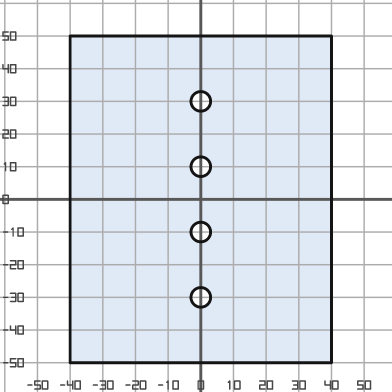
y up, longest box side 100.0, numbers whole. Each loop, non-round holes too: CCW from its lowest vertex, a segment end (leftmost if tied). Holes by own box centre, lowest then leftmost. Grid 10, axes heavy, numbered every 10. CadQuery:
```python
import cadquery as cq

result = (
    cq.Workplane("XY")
    .moveTo(-40.0, -50.0)
    .lineTo(40.0, -50.0)
    .lineTo(40.0, 50.0)
    .lineTo(-40.0, 50.0)
    .close()
    .moveTo(0.0, -30.0)
    .circle(3.0)
    .moveTo(0.0, -10.0)
    .circle(3.0)
    .moveTo(0.0, 10.0)
    .circle(3.0)
    .moveTo(0.0, 30.0)
    .circle(3.0)
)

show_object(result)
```